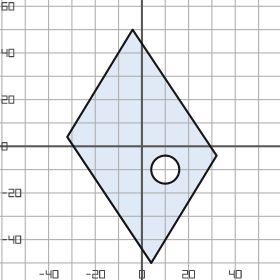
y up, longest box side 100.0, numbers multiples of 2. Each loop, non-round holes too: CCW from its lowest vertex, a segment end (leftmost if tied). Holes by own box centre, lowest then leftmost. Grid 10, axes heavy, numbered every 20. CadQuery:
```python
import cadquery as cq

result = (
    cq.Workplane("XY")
    .moveTo(4.0, -50.0)
    .lineTo(32.0, -4.0)
    .lineTo(-4.0, 50.0)
    .lineTo(-32.0, 4.0)
    .close()
    .moveTo(10.0, -10.0)
    .circle(6.0)
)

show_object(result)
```